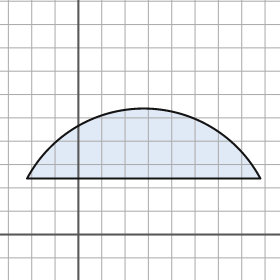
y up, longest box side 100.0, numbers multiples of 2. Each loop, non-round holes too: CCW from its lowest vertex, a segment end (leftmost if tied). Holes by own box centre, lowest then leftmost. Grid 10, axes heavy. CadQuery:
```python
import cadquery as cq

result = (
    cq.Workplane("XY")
    .moveTo(-22.0, 24.0)
    .lineTo(78.0, 24.0)
    .threePointArc((28.0, 54.0), (-22.0, 24.0))
    .close()
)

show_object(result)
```